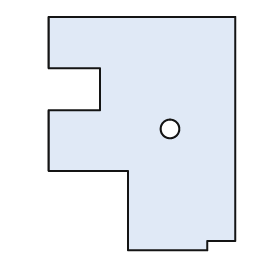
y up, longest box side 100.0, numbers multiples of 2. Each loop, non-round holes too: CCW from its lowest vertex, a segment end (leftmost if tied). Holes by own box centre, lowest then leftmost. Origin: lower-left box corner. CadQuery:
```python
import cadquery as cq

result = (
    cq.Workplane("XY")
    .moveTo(34.0, 0.0)
    .lineTo(68.0, 0.0)
    .lineTo(68.0, 4.0)
    .lineTo(80.0, 4.0)
    .lineTo(80.0, 100.0)
    .lineTo(0.0, 100.0)
    .lineTo(0.0, 78.0)
    .lineTo(22.0, 78.0)
    .lineTo(22.0, 60.0)
    .lineTo(0.0, 60.0)
    .lineTo(0.0, 34.0)
    .lineTo(34.0, 34.0)
    .close()
    .moveTo(52.0, 52.0)
    .circle(4.0)
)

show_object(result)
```